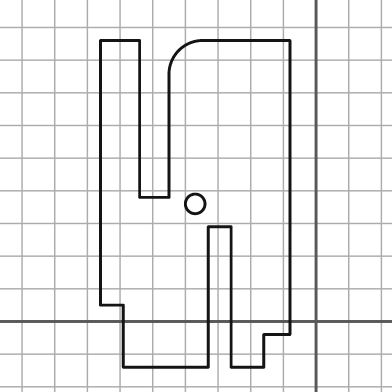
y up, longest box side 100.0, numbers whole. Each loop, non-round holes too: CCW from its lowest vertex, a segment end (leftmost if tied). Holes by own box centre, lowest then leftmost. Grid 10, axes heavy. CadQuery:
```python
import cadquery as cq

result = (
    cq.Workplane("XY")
    .moveTo(-59.0, -14.0)
    .lineTo(-33.0, -14.0)
    .lineTo(-33.0, 29.0)
    .lineTo(-26.0, 29.0)
    .lineTo(-26.0, -14.0)
    .lineTo(-16.0, -14.0)
    .lineTo(-16.0, -4.0)
    .lineTo(-8.0, -4.0)
    .lineTo(-8.0, 86.0)
    .lineTo(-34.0, 86.0)
    .threePointArc((-42.0, 83.0), (-45.0, 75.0))
    .lineTo(-45.0, 38.0)
    .lineTo(-54.0, 38.0)
    .lineTo(-54.0, 86.0)
    .lineTo(-66.0, 86.0)
    .lineTo(-66.0, 5.0)
    .lineTo(-59.0, 5.0)
    .close()
    .moveTo(-37.0, 36.0)
    .circle(3.0)
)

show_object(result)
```